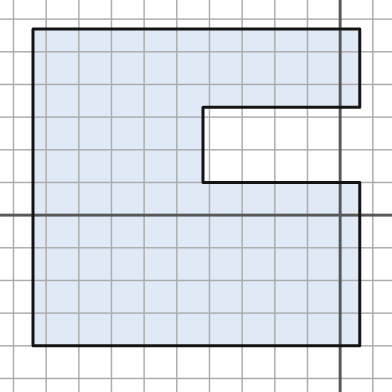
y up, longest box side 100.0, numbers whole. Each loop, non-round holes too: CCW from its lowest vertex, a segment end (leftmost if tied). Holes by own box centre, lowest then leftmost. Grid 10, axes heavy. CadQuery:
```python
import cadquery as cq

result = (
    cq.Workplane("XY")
    .moveTo(-94.0, -40.0)
    .lineTo(6.0, -40.0)
    .lineTo(6.0, 10.0)
    .lineTo(-42.0, 10.0)
    .lineTo(-42.0, 33.0)
    .lineTo(6.0, 33.0)
    .lineTo(6.0, 57.0)
    .lineTo(-94.0, 57.0)
    .close()
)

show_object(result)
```